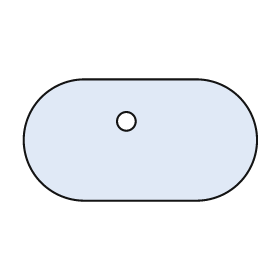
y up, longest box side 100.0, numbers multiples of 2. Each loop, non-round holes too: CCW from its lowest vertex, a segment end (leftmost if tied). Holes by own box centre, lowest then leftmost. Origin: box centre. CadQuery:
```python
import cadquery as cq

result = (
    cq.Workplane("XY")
    .moveTo(-24.0, -26.0)
    .lineTo(24.0, -26.0)
    .threePointArc((50.0, 0.0), (24.0, 26.0))
    .lineTo(-24.0, 26.0)
    .threePointArc((-50.0, 0.0), (-24.0, -26.0))
    .close()
    .moveTo(-6.0, 8.0)
    .circle(4.0)
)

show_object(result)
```